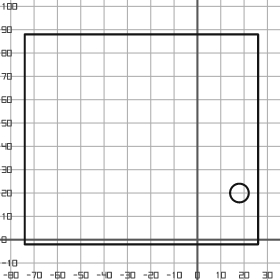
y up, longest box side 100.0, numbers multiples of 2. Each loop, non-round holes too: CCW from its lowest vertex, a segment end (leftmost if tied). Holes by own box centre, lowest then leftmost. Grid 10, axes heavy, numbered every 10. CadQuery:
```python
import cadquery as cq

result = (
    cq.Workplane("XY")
    .moveTo(-74.0, -2.0)
    .lineTo(26.0, -2.0)
    .lineTo(26.0, 88.0)
    .lineTo(-74.0, 88.0)
    .close()
    .moveTo(18.0, 20.0)
    .circle(4.0)
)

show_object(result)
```